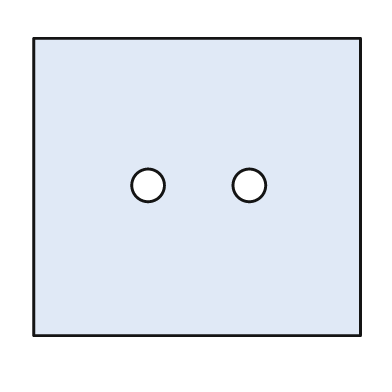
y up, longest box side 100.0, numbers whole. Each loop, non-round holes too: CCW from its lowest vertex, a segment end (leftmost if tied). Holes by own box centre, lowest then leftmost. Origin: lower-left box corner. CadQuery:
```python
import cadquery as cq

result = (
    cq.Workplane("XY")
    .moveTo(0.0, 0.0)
    .lineTo(100.0, 0.0)
    .lineTo(100.0, 91.0)
    .lineTo(0.0, 91.0)
    .close()
    .moveTo(35.0, 46.0)
    .circle(5.0)
    .moveTo(66.0, 46.0)
    .circle(5.0)
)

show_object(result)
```